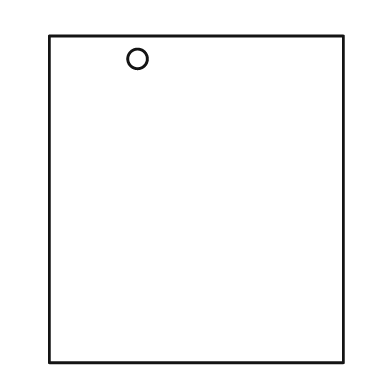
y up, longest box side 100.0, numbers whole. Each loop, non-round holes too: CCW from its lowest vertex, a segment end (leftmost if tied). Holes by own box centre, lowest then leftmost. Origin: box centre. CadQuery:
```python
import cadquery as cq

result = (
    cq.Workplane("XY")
    .moveTo(-45.0, -50.0)
    .lineTo(45.0, -50.0)
    .lineTo(45.0, 50.0)
    .lineTo(-45.0, 50.0)
    .close()
    .moveTo(-18.0, 43.0)
    .circle(3.0)
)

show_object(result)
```